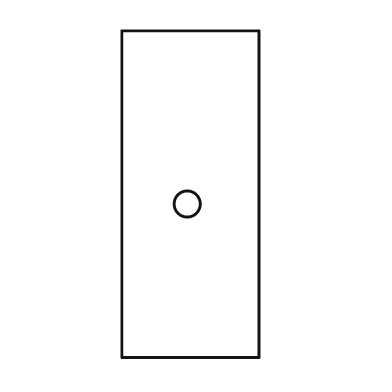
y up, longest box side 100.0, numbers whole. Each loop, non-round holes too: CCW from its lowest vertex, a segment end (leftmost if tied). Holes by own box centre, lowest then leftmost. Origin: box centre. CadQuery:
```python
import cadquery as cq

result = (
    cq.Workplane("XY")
    .moveTo(-21.0, -50.0)
    .lineTo(21.0, -50.0)
    .lineTo(21.0, 50.0)
    .lineTo(-21.0, 50.0)
    .close()
    .moveTo(-1.0, -3.0)
    .circle(4.0)
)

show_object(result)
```